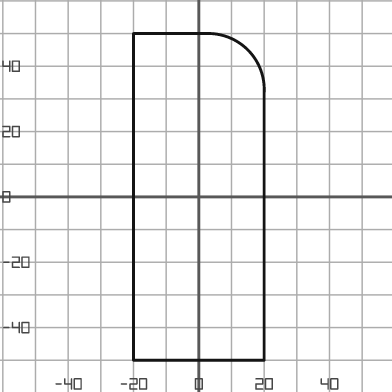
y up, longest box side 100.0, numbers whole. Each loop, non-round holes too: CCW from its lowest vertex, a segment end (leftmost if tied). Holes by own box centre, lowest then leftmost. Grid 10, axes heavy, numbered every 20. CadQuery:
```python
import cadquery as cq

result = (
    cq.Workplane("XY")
    .moveTo(-20.0, -50.0)
    .lineTo(20.0, -50.0)
    .lineTo(20.0, 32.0)
    .threePointArc((15.0, 45.0), (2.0, 50.0))
    .lineTo(-20.0, 50.0)
    .close()
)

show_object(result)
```